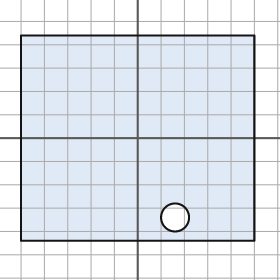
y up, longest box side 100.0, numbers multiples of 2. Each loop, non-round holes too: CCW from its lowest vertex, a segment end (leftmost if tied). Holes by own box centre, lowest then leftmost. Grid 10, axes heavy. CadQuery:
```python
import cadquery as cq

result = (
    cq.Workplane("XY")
    .moveTo(-50.0, -44.0)
    .lineTo(50.0, -44.0)
    .lineTo(50.0, 44.0)
    .lineTo(-50.0, 44.0)
    .close()
    .moveTo(16.0, -34.0)
    .circle(6.0)
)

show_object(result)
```